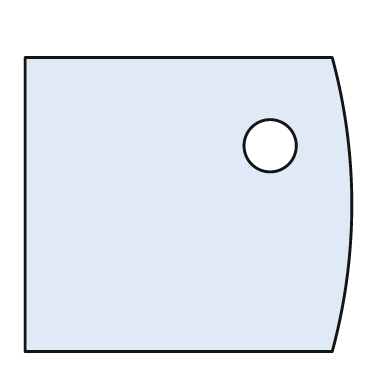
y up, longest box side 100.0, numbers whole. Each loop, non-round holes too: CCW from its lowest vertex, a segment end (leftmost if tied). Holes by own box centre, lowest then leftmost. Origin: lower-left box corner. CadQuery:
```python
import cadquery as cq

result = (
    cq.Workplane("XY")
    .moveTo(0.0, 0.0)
    .lineTo(94.0, 0.0)
    .threePointArc((100.0, 45.0), (94.0, 90.0))
    .lineTo(0.0, 90.0)
    .close()
    .moveTo(75.0, 63.0)
    .circle(8.0)
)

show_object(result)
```